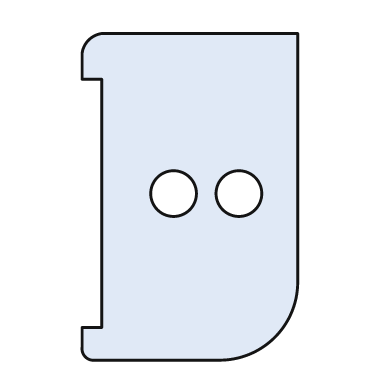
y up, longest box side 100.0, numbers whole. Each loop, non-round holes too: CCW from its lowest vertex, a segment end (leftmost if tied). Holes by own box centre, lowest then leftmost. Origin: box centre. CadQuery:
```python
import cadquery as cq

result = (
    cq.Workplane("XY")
    .moveTo(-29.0, -50.0)
    .lineTo(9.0, -50.0)
    .threePointArc((26.0, -43.0), (33.0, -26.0))
    .lineTo(33.0, 50.0)
    .lineTo(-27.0, 50.0)
    .threePointArc((-31.0, 48.0), (-33.0, 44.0))
    .lineTo(-33.0, 36.0)
    .lineTo(-27.0, 36.0)
    .lineTo(-27.0, -40.0)
    .lineTo(-33.0, -40.0)
    .lineTo(-33.0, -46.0)
    .threePointArc((-32.0, -49.0), (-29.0, -50.0))
    .close()
    .moveTo(-5.0, 1.0)
    .circle(7.0)
    .moveTo(15.0, 1.0)
    .circle(7.0)
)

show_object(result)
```